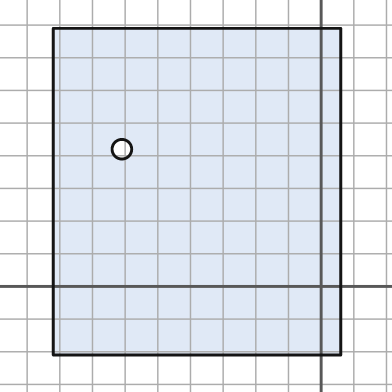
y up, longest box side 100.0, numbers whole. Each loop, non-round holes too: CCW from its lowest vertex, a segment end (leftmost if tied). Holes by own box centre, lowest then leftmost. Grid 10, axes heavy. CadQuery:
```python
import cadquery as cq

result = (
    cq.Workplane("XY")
    .moveTo(-82.0, -21.0)
    .lineTo(6.0, -21.0)
    .lineTo(6.0, 79.0)
    .lineTo(-82.0, 79.0)
    .close()
    .moveTo(-61.0, 42.0)
    .circle(3.0)
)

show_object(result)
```